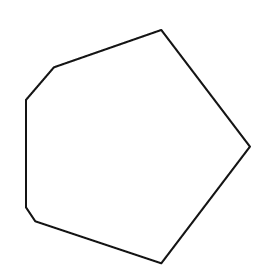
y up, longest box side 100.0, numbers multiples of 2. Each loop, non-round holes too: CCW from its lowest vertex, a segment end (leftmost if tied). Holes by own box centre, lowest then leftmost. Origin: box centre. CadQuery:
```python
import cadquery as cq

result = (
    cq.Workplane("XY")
    .moveTo(10.0, -50.0)
    .lineTo(48.0, 0.0)
    .lineTo(10.0, 50.0)
    .lineTo(-36.0, 34.0)
    .lineTo(-48.0, 20.0)
    .lineTo(-48.0, -26.0)
    .lineTo(-44.0, -32.0)
    .close()
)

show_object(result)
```